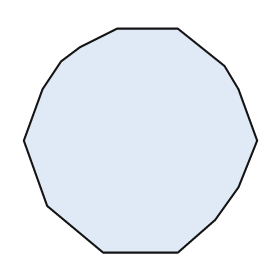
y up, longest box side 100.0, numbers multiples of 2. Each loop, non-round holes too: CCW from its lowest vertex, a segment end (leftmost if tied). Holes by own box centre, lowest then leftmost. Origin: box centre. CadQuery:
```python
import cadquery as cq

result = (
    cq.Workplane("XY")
    .moveTo(-16.0, -48.0)
    .lineTo(16.0, -48.0)
    .lineTo(32.0, -34.0)
    .lineTo(42.0, -20.0)
    .lineTo(50.0, 0.0)
    .lineTo(42.0, 22.0)
    .lineTo(36.0, 32.0)
    .lineTo(16.0, 48.0)
    .lineTo(-10.0, 48.0)
    .lineTo(-26.0, 40.0)
    .lineTo(-34.0, 34.0)
    .lineTo(-42.0, 22.0)
    .lineTo(-50.0, 0.0)
    .lineTo(-40.0, -28.0)
    .close()
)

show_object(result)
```